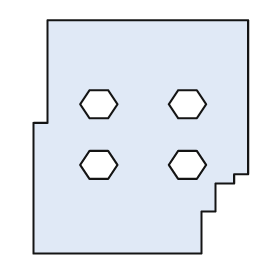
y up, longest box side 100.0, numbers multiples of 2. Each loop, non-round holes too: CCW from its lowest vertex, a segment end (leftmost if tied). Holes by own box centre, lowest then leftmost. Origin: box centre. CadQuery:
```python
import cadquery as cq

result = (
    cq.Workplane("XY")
    .moveTo(-46.0, -50.0)
    .lineTo(26.0, -50.0)
    .lineTo(26.0, -32.0)
    .lineTo(32.0, -32.0)
    .lineTo(32.0, -20.0)
    .lineTo(40.0, -20.0)
    .lineTo(40.0, -16.0)
    .lineTo(46.0, -16.0)
    .lineTo(46.0, 50.0)
    .lineTo(-40.0, 50.0)
    .lineTo(-40.0, 6.0)
    .lineTo(-46.0, 6.0)
    .close()
    .moveTo(-22.0, -18.0)
    .lineTo(-14.0, -18.0)
    .lineTo(-10.0, -12.0)
    .lineTo(-14.0, -6.0)
    .lineTo(-22.0, -6.0)
    .lineTo(-26.0, -12.0)
    .close()
    .moveTo(16.0, -18.0)
    .lineTo(24.0, -18.0)
    .lineTo(28.0, -12.0)
    .lineTo(24.0, -6.0)
    .lineTo(16.0, -6.0)
    .lineTo(12.0, -12.0)
    .close()
    .moveTo(-22.0, 8.0)
    .lineTo(-14.0, 8.0)
    .lineTo(-10.0, 14.0)
    .lineTo(-14.0, 20.0)
    .lineTo(-22.0, 20.0)
    .lineTo(-26.0, 14.0)
    .close()
    .moveTo(16.0, 8.0)
    .lineTo(24.0, 8.0)
    .lineTo(28.0, 14.0)
    .lineTo(24.0, 20.0)
    .lineTo(16.0, 20.0)
    .lineTo(12.0, 14.0)
    .close()
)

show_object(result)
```